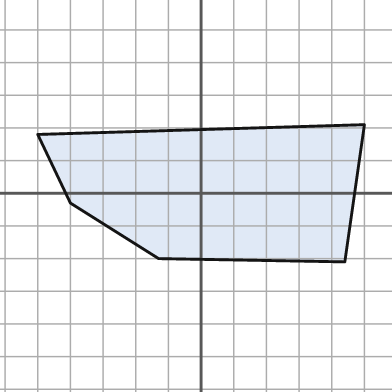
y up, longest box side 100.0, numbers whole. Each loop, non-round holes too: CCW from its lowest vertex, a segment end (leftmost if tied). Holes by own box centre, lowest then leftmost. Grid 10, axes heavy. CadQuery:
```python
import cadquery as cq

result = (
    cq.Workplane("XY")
    .moveTo(44.0, -21.0)
    .lineTo(50.0, 21.0)
    .lineTo(-50.0, 18.0)
    .lineTo(-40.0, -3.0)
    .lineTo(-13.0, -20.0)
    .close()
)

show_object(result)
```